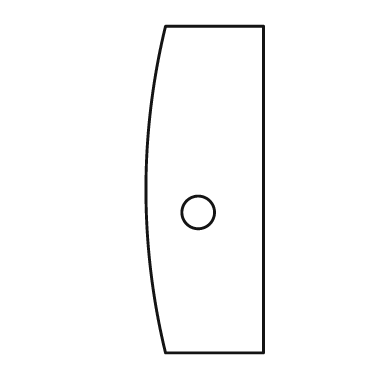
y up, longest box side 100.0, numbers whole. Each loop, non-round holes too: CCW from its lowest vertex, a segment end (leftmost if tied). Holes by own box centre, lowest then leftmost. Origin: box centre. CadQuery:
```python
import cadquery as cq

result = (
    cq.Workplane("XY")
    .moveTo(-12.0, -50.0)
    .lineTo(18.0, -50.0)
    .lineTo(18.0, 50.0)
    .lineTo(-12.0, 50.0)
    .threePointArc((-18.0, 0.0), (-12.0, -50.0))
    .close()
    .moveTo(-2.0, -7.0)
    .circle(5.0)
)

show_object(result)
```